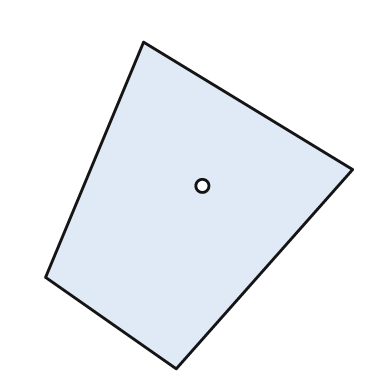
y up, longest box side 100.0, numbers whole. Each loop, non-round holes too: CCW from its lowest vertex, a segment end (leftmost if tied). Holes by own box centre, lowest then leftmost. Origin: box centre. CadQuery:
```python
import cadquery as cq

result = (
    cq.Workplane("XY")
    .moveTo(-7.0, -50.0)
    .lineTo(47.0, 11.0)
    .lineTo(-17.0, 50.0)
    .lineTo(-47.0, -22.0)
    .close()
    .moveTo(1.0, 6.0)
    .circle(2.0)
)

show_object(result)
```